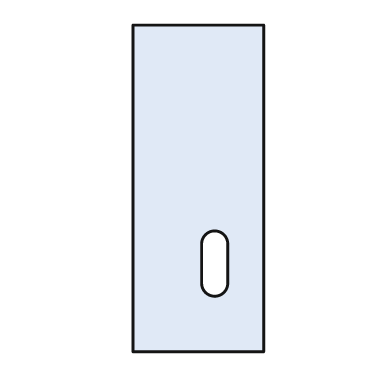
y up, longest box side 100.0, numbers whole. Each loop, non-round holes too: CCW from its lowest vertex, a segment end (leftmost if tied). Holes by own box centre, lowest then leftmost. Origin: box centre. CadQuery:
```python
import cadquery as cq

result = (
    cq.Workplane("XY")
    .moveTo(-20.0, -50.0)
    .lineTo(20.0, -50.0)
    .lineTo(20.0, 50.0)
    .lineTo(-20.0, 50.0)
    .close()
    .moveTo(1.0, -29.0)
    .threePointArc((5.0, -33.0), (9.0, -29.0))
    .lineTo(9.0, -17.0)
    .threePointArc((5.0, -13.0), (1.0, -17.0))
    .close()
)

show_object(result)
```